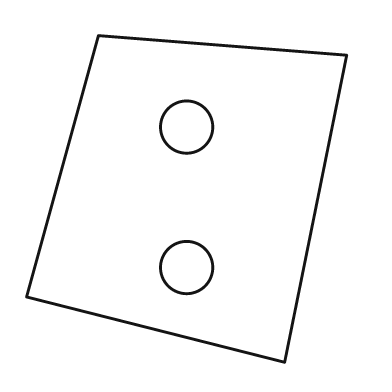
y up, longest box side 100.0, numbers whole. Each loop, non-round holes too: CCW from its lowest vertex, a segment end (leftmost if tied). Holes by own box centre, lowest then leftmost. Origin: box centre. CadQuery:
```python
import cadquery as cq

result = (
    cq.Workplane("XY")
    .moveTo(30.0, -50.0)
    .lineTo(49.0, 44.0)
    .lineTo(-27.0, 50.0)
    .lineTo(-49.0, -30.0)
    .close()
    .moveTo(0.0, -21.0)
    .circle(8.0)
    .moveTo(0.0, 22.0)
    .circle(8.0)
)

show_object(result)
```